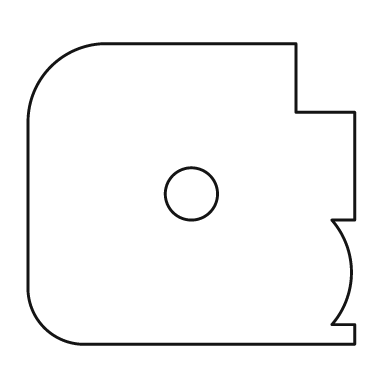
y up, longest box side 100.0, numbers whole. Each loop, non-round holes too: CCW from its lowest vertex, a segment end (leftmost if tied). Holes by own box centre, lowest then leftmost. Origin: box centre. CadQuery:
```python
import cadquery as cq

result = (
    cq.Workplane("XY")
    .moveTo(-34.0, -46.0)
    .lineTo(50.0, -46.0)
    .lineTo(50.0, -40.0)
    .lineTo(43.0, -40.0)
    .threePointArc((49.0, -24.0), (43.0, -8.0))
    .lineTo(50.0, -8.0)
    .lineTo(50.0, 25.0)
    .lineTo(32.0, 25.0)
    .lineTo(32.0, 46.0)
    .lineTo(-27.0, 46.0)
    .threePointArc((-43.0, 39.0), (-50.0, 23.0))
    .lineTo(-50.0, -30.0)
    .threePointArc((-45.0, -41.0), (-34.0, -46.0))
    .close()
    .moveTo(0.0, 0.0)
    .circle(8.0)
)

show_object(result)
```